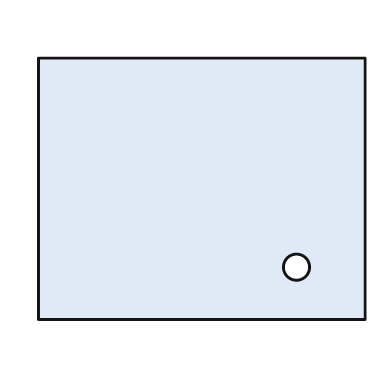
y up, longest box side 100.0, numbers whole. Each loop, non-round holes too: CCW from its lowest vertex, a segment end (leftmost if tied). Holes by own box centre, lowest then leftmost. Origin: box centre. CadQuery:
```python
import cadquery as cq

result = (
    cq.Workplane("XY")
    .moveTo(-50.0, -40.0)
    .lineTo(50.0, -40.0)
    .lineTo(50.0, 40.0)
    .lineTo(-50.0, 40.0)
    .close()
    .moveTo(29.0, -24.0)
    .circle(4.0)
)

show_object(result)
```